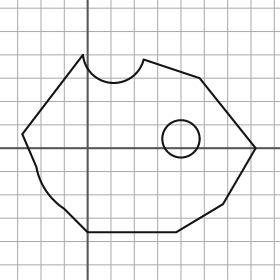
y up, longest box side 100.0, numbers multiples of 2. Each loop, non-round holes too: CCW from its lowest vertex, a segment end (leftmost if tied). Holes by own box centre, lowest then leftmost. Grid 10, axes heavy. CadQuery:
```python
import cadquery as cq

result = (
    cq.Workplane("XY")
    .moveTo(0.0, -36.0)
    .lineTo(38.0, -36.0)
    .lineTo(58.0, -24.0)
    .lineTo(72.0, 0.0)
    .lineTo(48.0, 30.0)
    .lineTo(24.0, 38.0)
    .threePointArc((10.0, 28.0), (-2.0, 40.0))
    .lineTo(-28.0, 6.0)
    .lineTo(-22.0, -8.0)
    .threePointArc((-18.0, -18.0), (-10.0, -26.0))
    .close()
    .moveTo(40.0, 4.0)
    .circle(8.0)
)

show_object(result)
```